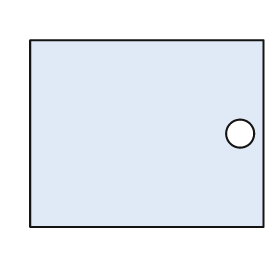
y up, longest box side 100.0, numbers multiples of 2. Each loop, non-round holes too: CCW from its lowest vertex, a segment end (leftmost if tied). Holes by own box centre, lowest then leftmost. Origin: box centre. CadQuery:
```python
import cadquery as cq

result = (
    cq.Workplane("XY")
    .moveTo(-50.0, -40.0)
    .lineTo(50.0, -40.0)
    .lineTo(50.0, 40.0)
    .lineTo(-50.0, 40.0)
    .close()
    .moveTo(40.0, 0.0)
    .circle(6.0)
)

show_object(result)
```